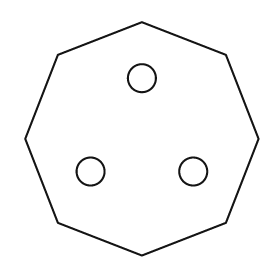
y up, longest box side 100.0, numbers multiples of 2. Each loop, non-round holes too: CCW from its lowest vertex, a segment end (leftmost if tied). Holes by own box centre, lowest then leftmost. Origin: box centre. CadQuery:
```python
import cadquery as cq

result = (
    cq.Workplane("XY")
    .moveTo(0.0, -50.0)
    .lineTo(36.0, -36.0)
    .lineTo(50.0, 0.0)
    .lineTo(36.0, 36.0)
    .lineTo(0.0, 50.0)
    .lineTo(-36.0, 36.0)
    .lineTo(-50.0, 0.0)
    .lineTo(-36.0, -36.0)
    .close()
    .moveTo(-22.0, -14.0)
    .circle(6.0)
    .moveTo(22.0, -14.0)
    .circle(6.0)
    .moveTo(0.0, 26.0)
    .circle(6.0)
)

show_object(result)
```